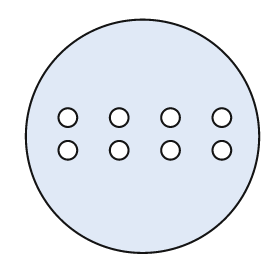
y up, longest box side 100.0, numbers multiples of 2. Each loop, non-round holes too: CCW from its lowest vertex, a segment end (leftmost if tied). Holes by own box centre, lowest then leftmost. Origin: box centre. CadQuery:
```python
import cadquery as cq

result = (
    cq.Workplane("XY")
    .moveTo(0.0, 0.0)
    .circle(50.0)
    .moveTo(-32.0, -6.0)
    .circle(4.0)
    .moveTo(-10.0, -6.0)
    .circle(4.0)
    .moveTo(12.0, -6.0)
    .circle(4.0)
    .moveTo(34.0, -6.0)
    .circle(4.0)
    .moveTo(-32.0, 8.0)
    .circle(4.0)
    .moveTo(-10.0, 8.0)
    .circle(4.0)
    .moveTo(12.0, 8.0)
    .circle(4.0)
    .moveTo(34.0, 8.0)
    .circle(4.0)
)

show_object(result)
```